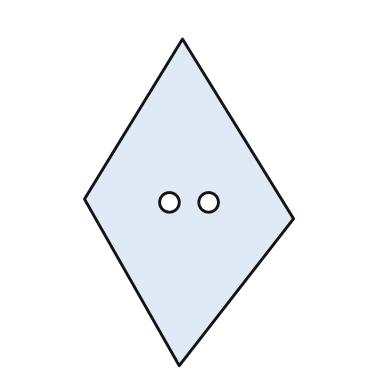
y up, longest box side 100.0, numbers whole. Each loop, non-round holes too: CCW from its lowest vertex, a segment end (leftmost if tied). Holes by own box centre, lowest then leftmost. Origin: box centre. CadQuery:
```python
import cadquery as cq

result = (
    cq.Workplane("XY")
    .moveTo(-3.0, -50.0)
    .lineTo(32.0, -5.0)
    .lineTo(-2.0, 50.0)
    .lineTo(-32.0, 1.0)
    .close()
    .moveTo(-6.0, 0.0)
    .circle(3.0)
    .moveTo(6.0, 0.0)
    .circle(3.0)
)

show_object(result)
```